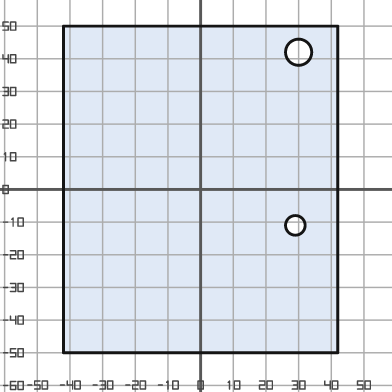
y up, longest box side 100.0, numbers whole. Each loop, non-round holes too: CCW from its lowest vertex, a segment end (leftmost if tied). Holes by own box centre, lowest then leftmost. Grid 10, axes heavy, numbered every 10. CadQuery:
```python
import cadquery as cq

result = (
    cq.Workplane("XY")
    .moveTo(-42.0, -50.0)
    .lineTo(42.0, -50.0)
    .lineTo(42.0, 50.0)
    .lineTo(-42.0, 50.0)
    .close()
    .moveTo(29.0, -11.0)
    .circle(3.0)
    .moveTo(30.0, 42.0)
    .circle(4.0)
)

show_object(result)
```